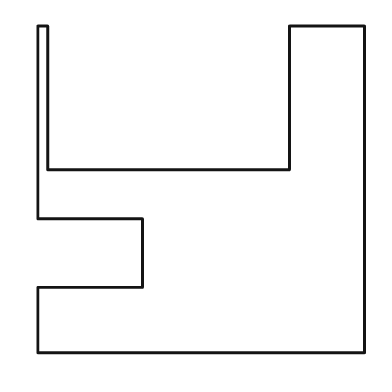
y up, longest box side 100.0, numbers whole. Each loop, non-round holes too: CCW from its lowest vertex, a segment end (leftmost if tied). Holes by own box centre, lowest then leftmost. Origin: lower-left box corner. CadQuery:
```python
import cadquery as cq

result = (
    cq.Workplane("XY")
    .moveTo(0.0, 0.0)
    .lineTo(100.0, 0.0)
    .lineTo(100.0, 100.0)
    .lineTo(77.0, 100.0)
    .lineTo(77.0, 56.0)
    .lineTo(3.0, 56.0)
    .lineTo(3.0, 100.0)
    .lineTo(0.0, 100.0)
    .lineTo(0.0, 41.0)
    .lineTo(32.0, 41.0)
    .lineTo(32.0, 20.0)
    .lineTo(0.0, 20.0)
    .close()
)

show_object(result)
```